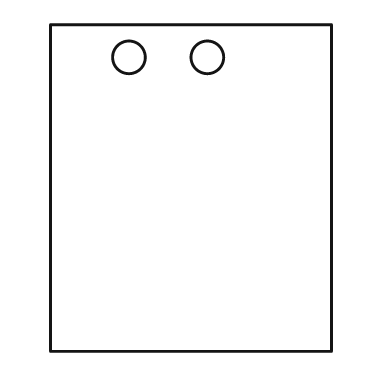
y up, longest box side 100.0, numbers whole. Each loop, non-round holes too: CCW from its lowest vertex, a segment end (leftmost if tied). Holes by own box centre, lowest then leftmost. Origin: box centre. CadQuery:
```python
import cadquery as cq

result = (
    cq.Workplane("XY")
    .moveTo(-43.0, -50.0)
    .lineTo(43.0, -50.0)
    .lineTo(43.0, 50.0)
    .lineTo(-43.0, 50.0)
    .close()
    .moveTo(-19.0, 40.0)
    .circle(5.0)
    .moveTo(5.0, 40.0)
    .circle(5.0)
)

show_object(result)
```